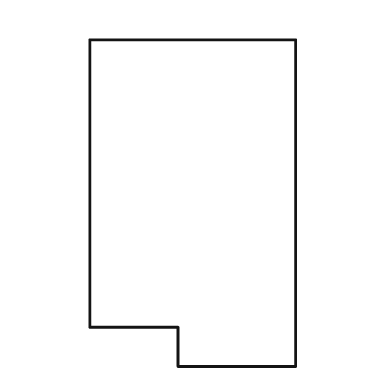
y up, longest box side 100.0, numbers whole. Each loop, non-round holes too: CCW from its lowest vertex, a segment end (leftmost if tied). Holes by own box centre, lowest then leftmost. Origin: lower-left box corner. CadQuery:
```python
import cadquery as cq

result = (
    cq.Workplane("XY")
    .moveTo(27.0, 0.0)
    .lineTo(63.0, 0.0)
    .lineTo(63.0, 100.0)
    .lineTo(0.0, 100.0)
    .lineTo(0.0, 12.0)
    .lineTo(27.0, 12.0)
    .close()
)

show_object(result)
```